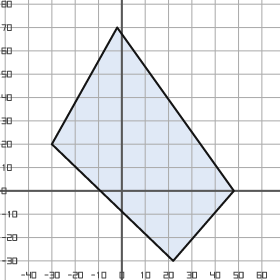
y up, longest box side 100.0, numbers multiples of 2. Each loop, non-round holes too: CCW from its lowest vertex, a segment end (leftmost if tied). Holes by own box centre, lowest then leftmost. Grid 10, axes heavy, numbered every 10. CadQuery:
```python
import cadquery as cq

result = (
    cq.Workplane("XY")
    .moveTo(22.0, -30.0)
    .lineTo(48.0, 0.0)
    .lineTo(-2.0, 70.0)
    .lineTo(-30.0, 20.0)
    .close()
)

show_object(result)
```